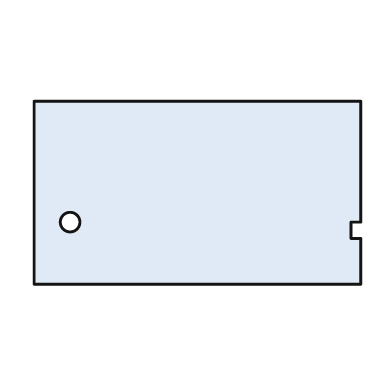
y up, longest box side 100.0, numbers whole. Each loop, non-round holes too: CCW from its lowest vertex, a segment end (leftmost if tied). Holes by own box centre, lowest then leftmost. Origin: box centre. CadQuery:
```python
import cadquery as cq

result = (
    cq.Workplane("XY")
    .moveTo(-50.0, -28.0)
    .lineTo(50.0, -28.0)
    .lineTo(50.0, -14.0)
    .lineTo(47.0, -14.0)
    .lineTo(47.0, -9.0)
    .lineTo(50.0, -9.0)
    .lineTo(50.0, 28.0)
    .lineTo(-50.0, 28.0)
    .close()
    .moveTo(-39.0, -9.0)
    .circle(3.0)
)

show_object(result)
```